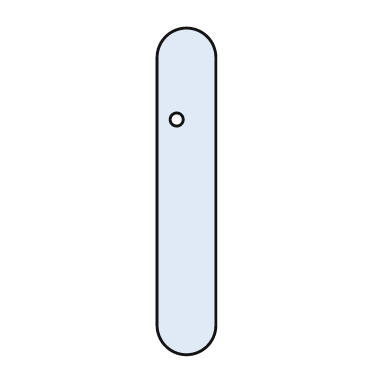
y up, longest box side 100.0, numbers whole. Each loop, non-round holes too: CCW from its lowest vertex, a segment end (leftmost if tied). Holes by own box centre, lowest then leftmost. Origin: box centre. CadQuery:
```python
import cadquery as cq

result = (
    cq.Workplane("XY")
    .moveTo(-9.0, -41.0)
    .threePointArc((0.0, -50.0), (9.0, -41.0))
    .lineTo(9.0, 41.0)
    .threePointArc((0.0, 50.0), (-9.0, 41.0))
    .close()
    .moveTo(-3.0, 22.0)
    .circle(2.0)
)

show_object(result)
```